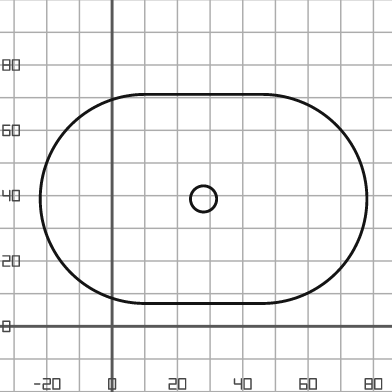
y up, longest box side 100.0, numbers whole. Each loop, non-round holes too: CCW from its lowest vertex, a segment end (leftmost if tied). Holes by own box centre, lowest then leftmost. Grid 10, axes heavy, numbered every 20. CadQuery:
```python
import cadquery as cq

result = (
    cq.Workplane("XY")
    .moveTo(10.0, 7.0)
    .lineTo(46.0, 7.0)
    .threePointArc((78.0, 39.0), (46.0, 71.0))
    .lineTo(10.0, 71.0)
    .threePointArc((-22.0, 39.0), (10.0, 7.0))
    .close()
    .moveTo(28.0, 39.0)
    .circle(4.0)
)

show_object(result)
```